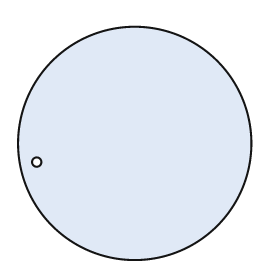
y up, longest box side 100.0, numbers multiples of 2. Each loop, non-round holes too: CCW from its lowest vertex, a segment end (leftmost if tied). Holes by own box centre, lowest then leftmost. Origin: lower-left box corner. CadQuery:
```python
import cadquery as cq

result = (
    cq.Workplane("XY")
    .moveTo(50.0, 50.0)
    .circle(50.0)
    .moveTo(8.0, 42.0)
    .circle(2.0)
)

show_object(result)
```